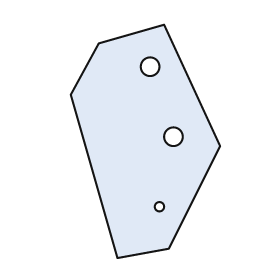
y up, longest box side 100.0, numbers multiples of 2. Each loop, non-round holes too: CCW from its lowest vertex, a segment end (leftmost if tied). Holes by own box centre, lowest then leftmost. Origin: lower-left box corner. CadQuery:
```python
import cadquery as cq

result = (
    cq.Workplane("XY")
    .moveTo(20.0, 0.0)
    .lineTo(42.0, 4.0)
    .lineTo(64.0, 48.0)
    .lineTo(40.0, 100.0)
    .lineTo(12.0, 92.0)
    .lineTo(0.0, 70.0)
    .close()
    .moveTo(38.0, 22.0)
    .circle(2.0)
    .moveTo(44.0, 52.0)
    .circle(4.0)
    .moveTo(34.0, 82.0)
    .circle(4.0)
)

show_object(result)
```